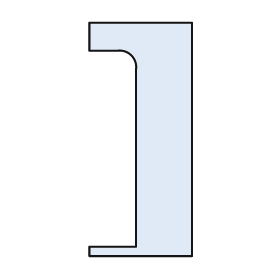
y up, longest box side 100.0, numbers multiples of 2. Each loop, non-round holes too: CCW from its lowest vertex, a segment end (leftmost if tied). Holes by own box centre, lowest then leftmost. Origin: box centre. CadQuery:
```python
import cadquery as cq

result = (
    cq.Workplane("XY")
    .moveTo(-22.0, -50.0)
    .lineTo(22.0, -50.0)
    .lineTo(22.0, 50.0)
    .lineTo(-22.0, 50.0)
    .lineTo(-22.0, 38.0)
    .lineTo(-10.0, 38.0)
    .threePointArc((-4.0, 36.0), (-2.0, 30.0))
    .lineTo(-2.0, -46.0)
    .lineTo(-22.0, -46.0)
    .close()
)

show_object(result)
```